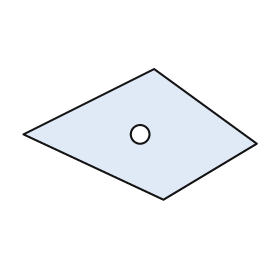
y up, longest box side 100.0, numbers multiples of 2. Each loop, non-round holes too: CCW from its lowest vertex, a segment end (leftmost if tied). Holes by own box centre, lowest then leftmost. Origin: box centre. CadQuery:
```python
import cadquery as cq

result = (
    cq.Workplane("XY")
    .moveTo(10.0, -28.0)
    .lineTo(50.0, -4.0)
    .lineTo(6.0, 28.0)
    .lineTo(-50.0, 0.0)
    .close()
    .moveTo(0.0, 0.0)
    .circle(4.0)
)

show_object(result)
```